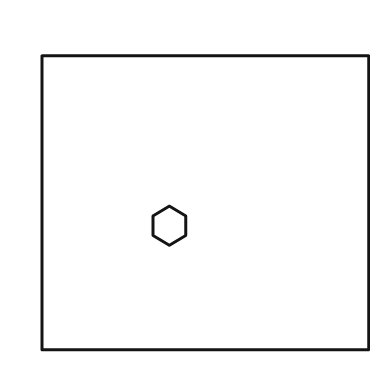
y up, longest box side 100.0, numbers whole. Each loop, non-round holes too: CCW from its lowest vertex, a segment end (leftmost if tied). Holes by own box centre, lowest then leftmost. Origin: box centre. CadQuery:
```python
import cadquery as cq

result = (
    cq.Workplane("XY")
    .moveTo(-50.0, -45.0)
    .lineTo(50.0, -45.0)
    .lineTo(50.0, 45.0)
    .lineTo(-50.0, 45.0)
    .close()
    .moveTo(-11.0, -13.0)
    .lineTo(-6.0, -10.0)
    .lineTo(-6.0, -4.0)
    .lineTo(-11.0, -1.0)
    .lineTo(-16.0, -4.0)
    .lineTo(-16.0, -10.0)
    .close()
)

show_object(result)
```